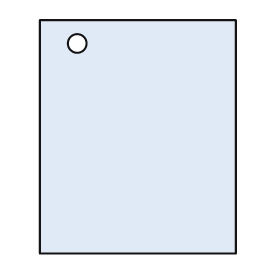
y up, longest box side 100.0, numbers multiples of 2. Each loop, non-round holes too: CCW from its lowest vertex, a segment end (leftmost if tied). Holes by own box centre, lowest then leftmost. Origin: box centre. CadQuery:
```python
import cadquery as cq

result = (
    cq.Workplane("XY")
    .moveTo(-42.0, -50.0)
    .lineTo(42.0, -50.0)
    .lineTo(42.0, 50.0)
    .lineTo(-42.0, 50.0)
    .close()
    .moveTo(-26.0, 40.0)
    .circle(4.0)
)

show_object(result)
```